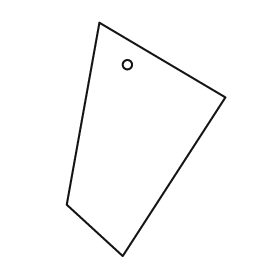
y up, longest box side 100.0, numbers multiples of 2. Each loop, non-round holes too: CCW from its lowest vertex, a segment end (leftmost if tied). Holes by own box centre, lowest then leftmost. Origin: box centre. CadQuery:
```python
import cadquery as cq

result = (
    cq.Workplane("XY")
    .moveTo(-10.0, -50.0)
    .lineTo(34.0, 18.0)
    .lineTo(-20.0, 50.0)
    .lineTo(-34.0, -28.0)
    .close()
    .moveTo(-8.0, 32.0)
    .circle(2.0)
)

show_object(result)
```